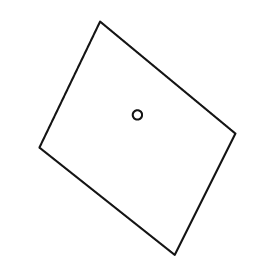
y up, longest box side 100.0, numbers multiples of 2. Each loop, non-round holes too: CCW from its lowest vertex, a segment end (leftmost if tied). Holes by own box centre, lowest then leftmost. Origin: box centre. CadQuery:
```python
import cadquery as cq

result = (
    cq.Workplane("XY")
    .moveTo(16.0, -50.0)
    .lineTo(42.0, 2.0)
    .lineTo(-16.0, 50.0)
    .lineTo(-42.0, -4.0)
    .close()
    .moveTo(0.0, 10.0)
    .circle(2.0)
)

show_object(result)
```